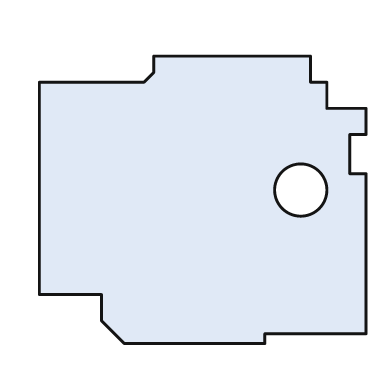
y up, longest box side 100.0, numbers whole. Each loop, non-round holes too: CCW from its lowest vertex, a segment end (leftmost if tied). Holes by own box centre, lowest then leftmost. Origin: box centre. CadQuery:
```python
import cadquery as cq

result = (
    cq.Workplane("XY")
    .moveTo(-24.0, -44.0)
    .lineTo(19.0, -44.0)
    .lineTo(19.0, -41.0)
    .lineTo(50.0, -41.0)
    .lineTo(50.0, 8.0)
    .lineTo(45.0, 8.0)
    .lineTo(45.0, 20.0)
    .lineTo(50.0, 20.0)
    .lineTo(50.0, 28.0)
    .lineTo(38.0, 28.0)
    .lineTo(38.0, 36.0)
    .lineTo(33.0, 36.0)
    .lineTo(33.0, 44.0)
    .lineTo(-15.0, 44.0)
    .lineTo(-15.0, 39.0)
    .lineTo(-18.0, 36.0)
    .lineTo(-50.0, 36.0)
    .lineTo(-50.0, -29.0)
    .lineTo(-31.0, -29.0)
    .lineTo(-31.0, -37.0)
    .close()
    .moveTo(30.0, 3.0)
    .circle(8.0)
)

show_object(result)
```